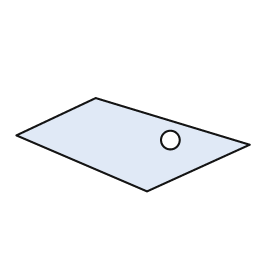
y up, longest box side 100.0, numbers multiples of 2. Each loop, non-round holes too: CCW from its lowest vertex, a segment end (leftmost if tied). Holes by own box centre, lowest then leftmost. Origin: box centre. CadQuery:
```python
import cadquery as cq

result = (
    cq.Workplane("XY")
    .moveTo(6.0, -20.0)
    .lineTo(50.0, 0.0)
    .lineTo(-16.0, 20.0)
    .lineTo(-50.0, 4.0)
    .close()
    .moveTo(16.0, 2.0)
    .circle(4.0)
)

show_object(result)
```